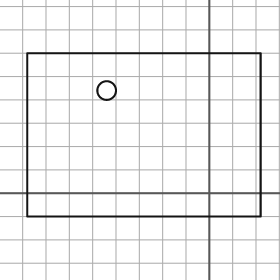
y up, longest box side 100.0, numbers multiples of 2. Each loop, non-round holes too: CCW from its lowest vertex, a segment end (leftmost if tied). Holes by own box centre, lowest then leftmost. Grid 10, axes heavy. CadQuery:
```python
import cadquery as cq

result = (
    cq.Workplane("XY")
    .moveTo(-78.0, -10.0)
    .lineTo(22.0, -10.0)
    .lineTo(22.0, 60.0)
    .lineTo(-78.0, 60.0)
    .close()
    .moveTo(-44.0, 44.0)
    .circle(4.0)
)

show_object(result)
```